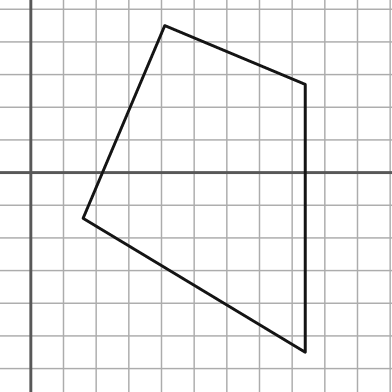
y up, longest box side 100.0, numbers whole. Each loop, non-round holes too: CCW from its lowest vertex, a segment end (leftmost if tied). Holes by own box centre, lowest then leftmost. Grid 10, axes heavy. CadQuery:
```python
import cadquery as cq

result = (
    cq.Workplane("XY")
    .moveTo(84.0, -55.0)
    .lineTo(84.0, 27.0)
    .lineTo(41.0, 45.0)
    .lineTo(16.0, -14.0)
    .close()
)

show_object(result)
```